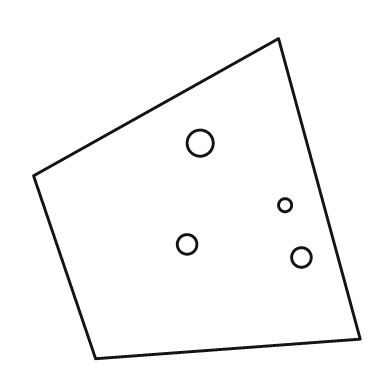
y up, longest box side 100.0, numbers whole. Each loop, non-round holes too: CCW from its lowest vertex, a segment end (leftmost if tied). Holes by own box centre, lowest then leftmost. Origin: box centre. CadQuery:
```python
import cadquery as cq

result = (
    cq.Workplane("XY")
    .moveTo(-31.0, -49.0)
    .lineTo(50.0, -43.0)
    .lineTo(25.0, 49.0)
    .lineTo(-50.0, 7.0)
    .close()
    .moveTo(32.0, -18.0)
    .circle(3.0)
    .moveTo(-3.0, -14.0)
    .circle(3.0)
    .moveTo(27.0, -2.0)
    .circle(2.0)
    .moveTo(1.0, 17.0)
    .circle(4.0)
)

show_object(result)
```